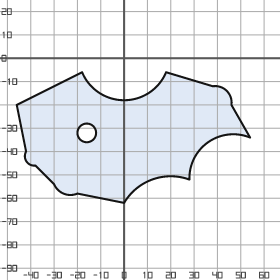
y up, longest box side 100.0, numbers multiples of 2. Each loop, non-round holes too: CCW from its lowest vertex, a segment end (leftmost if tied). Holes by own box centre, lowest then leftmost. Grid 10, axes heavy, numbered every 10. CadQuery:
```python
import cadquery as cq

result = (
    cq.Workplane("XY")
    .moveTo(0.0, -62.0)
    .threePointArc((12.0, -52.0), (28.0, -52.0))
    .threePointArc((36.0, -36.0), (54.0, -34.0))
    .lineTo(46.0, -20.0)
    .threePointArc((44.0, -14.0), (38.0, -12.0))
    .lineTo(18.0, -6.0)
    .threePointArc((0.0, -18.0), (-18.0, -6.0))
    .lineTo(-46.0, -20.0)
    .lineTo(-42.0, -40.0)
    .threePointArc((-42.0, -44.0), (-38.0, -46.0))
    .lineTo(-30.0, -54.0)
    .threePointArc((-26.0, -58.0), (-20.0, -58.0))
    .close()
    .moveTo(-16.0, -32.0)
    .circle(4.0)
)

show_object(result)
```